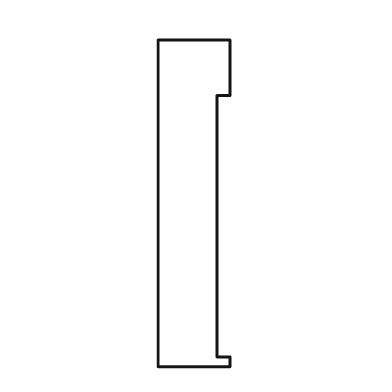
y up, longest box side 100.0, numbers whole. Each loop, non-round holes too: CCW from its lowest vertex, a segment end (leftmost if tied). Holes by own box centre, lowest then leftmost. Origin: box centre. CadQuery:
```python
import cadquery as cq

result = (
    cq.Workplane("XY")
    .moveTo(-11.0, -50.0)
    .lineTo(11.0, -50.0)
    .lineTo(11.0, -47.0)
    .lineTo(7.0, -47.0)
    .lineTo(7.0, 33.0)
    .lineTo(11.0, 33.0)
    .lineTo(11.0, 50.0)
    .lineTo(-11.0, 50.0)
    .close()
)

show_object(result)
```